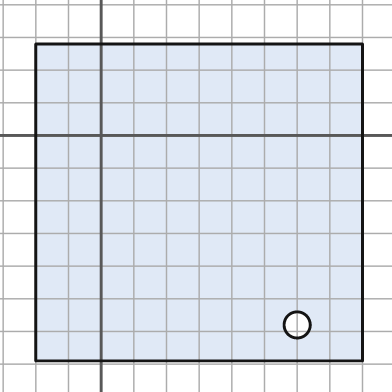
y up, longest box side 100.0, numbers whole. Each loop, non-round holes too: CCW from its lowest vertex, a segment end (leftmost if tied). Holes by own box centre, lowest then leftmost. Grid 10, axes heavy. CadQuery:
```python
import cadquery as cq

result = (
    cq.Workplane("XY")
    .moveTo(-20.0, -69.0)
    .lineTo(80.0, -69.0)
    .lineTo(80.0, 28.0)
    .lineTo(-20.0, 28.0)
    .close()
    .moveTo(60.0, -58.0)
    .circle(4.0)
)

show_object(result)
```